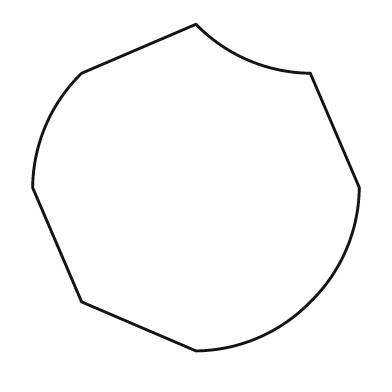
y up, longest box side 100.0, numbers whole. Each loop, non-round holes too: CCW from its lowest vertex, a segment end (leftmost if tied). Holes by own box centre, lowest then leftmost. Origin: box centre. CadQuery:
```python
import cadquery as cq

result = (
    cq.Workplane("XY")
    .moveTo(0.0, -50.0)
    .threePointArc((19.0, -46.0), (35.0, -35.0))
    .threePointArc((46.0, -19.0), (50.0, 0.0))
    .lineTo(35.0, 35.0)
    .threePointArc((16.0, 39.0), (0.0, 50.0))
    .lineTo(-35.0, 35.0)
    .threePointArc((-46.0, 19.0), (-50.0, 0.0))
    .lineTo(-35.0, -35.0)
    .close()
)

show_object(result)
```